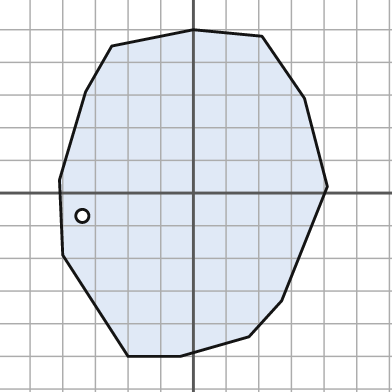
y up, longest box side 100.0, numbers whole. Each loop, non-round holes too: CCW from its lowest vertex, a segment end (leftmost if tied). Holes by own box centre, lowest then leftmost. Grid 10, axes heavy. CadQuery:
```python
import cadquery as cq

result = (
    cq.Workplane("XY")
    .moveTo(-20.0, -50.0)
    .lineTo(-4.0, -50.0)
    .lineTo(17.0, -44.0)
    .lineTo(27.0, -33.0)
    .lineTo(41.0, 2.0)
    .lineTo(34.0, 29.0)
    .lineTo(21.0, 48.0)
    .lineTo(0.0, 50.0)
    .lineTo(-25.0, 45.0)
    .lineTo(-33.0, 31.0)
    .lineTo(-41.0, 4.0)
    .lineTo(-40.0, -19.0)
    .close()
    .moveTo(-34.0, -7.0)
    .circle(2.0)
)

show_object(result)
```